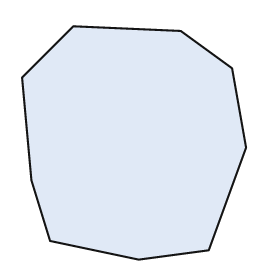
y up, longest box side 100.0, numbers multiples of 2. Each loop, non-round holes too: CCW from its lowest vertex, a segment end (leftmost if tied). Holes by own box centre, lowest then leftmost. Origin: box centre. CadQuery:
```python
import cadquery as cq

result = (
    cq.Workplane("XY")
    .moveTo(2.0, -50.0)
    .lineTo(32.0, -46.0)
    .lineTo(48.0, -2.0)
    .lineTo(42.0, 32.0)
    .lineTo(20.0, 48.0)
    .lineTo(-26.0, 50.0)
    .lineTo(-48.0, 28.0)
    .lineTo(-44.0, -16.0)
    .lineTo(-36.0, -42.0)
    .close()
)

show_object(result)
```